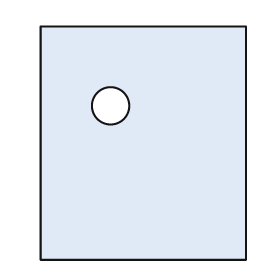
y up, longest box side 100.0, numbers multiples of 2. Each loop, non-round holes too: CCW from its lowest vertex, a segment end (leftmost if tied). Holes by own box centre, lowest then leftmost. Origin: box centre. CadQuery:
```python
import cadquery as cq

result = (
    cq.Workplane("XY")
    .moveTo(-44.0, -50.0)
    .lineTo(44.0, -50.0)
    .lineTo(44.0, 50.0)
    .lineTo(-44.0, 50.0)
    .close()
    .moveTo(-14.0, 16.0)
    .circle(8.0)
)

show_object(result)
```